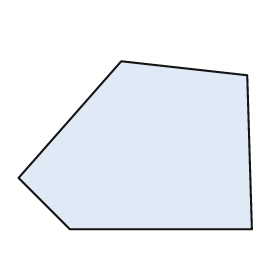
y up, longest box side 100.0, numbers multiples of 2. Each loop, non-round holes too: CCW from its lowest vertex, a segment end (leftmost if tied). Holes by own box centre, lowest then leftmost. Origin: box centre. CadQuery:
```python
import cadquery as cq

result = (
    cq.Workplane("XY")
    .moveTo(-28.0, -36.0)
    .lineTo(50.0, -36.0)
    .lineTo(48.0, 30.0)
    .lineTo(-6.0, 36.0)
    .lineTo(-50.0, -14.0)
    .close()
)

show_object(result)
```